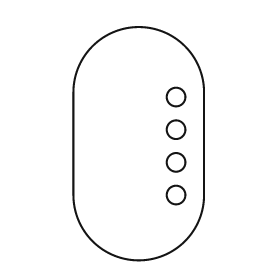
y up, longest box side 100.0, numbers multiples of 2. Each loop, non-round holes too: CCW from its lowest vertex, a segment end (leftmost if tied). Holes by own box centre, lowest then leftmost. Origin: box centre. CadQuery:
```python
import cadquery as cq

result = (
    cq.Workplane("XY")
    .moveTo(-28.0, -22.0)
    .threePointArc((0.0, -50.0), (28.0, -22.0))
    .lineTo(28.0, 22.0)
    .threePointArc((0.0, 50.0), (-28.0, 22.0))
    .close()
    .moveTo(16.0, -22.0)
    .circle(4.0)
    .moveTo(16.0, -8.0)
    .circle(4.0)
    .moveTo(16.0, 6.0)
    .circle(4.0)
    .moveTo(16.0, 20.0)
    .circle(4.0)
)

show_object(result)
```